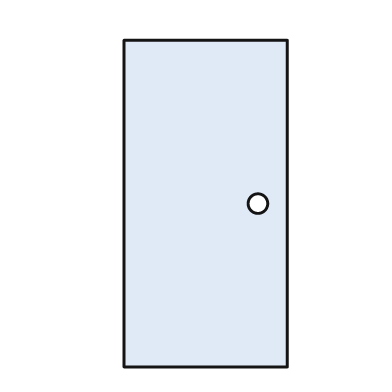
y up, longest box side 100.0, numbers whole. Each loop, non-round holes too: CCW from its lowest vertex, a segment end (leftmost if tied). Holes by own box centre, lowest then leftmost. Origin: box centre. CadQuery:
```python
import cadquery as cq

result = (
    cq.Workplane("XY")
    .moveTo(-25.0, -50.0)
    .lineTo(25.0, -50.0)
    .lineTo(25.0, 50.0)
    .lineTo(-25.0, 50.0)
    .close()
    .moveTo(16.0, 0.0)
    .circle(3.0)
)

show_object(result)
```